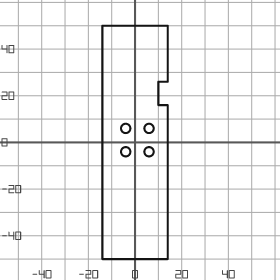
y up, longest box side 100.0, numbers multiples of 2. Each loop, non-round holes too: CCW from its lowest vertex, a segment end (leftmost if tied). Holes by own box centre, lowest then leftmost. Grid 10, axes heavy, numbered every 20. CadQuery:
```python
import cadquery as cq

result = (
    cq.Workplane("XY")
    .moveTo(-14.0, -50.0)
    .lineTo(14.0, -50.0)
    .lineTo(14.0, 16.0)
    .lineTo(10.0, 16.0)
    .lineTo(10.0, 26.0)
    .lineTo(14.0, 26.0)
    .lineTo(14.0, 50.0)
    .lineTo(-14.0, 50.0)
    .close()
    .moveTo(-4.0, -4.0)
    .circle(2.0)
    .moveTo(6.0, -4.0)
    .circle(2.0)
    .moveTo(-4.0, 6.0)
    .circle(2.0)
    .moveTo(6.0, 6.0)
    .circle(2.0)
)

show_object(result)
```